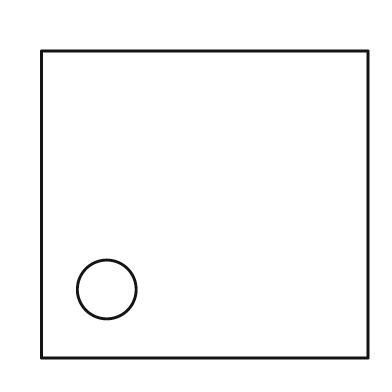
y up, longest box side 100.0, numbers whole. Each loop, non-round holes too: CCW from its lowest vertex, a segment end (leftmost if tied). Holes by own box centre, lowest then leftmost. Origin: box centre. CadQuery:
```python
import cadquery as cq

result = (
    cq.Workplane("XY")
    .moveTo(-50.0, -47.0)
    .lineTo(50.0, -47.0)
    .lineTo(50.0, 47.0)
    .lineTo(-50.0, 47.0)
    .close()
    .moveTo(-30.0, -26.0)
    .circle(9.0)
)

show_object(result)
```